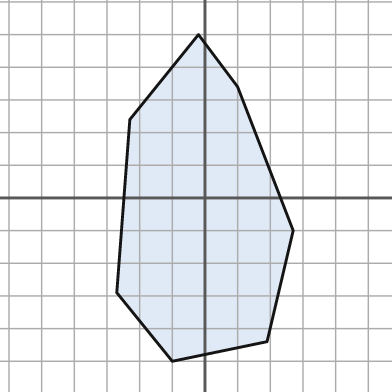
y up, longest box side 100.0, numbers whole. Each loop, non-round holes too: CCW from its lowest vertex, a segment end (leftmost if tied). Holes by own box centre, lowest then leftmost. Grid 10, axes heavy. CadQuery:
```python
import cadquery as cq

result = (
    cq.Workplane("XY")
    .moveTo(-10.0, -50.0)
    .lineTo(19.0, -44.0)
    .lineTo(27.0, -10.0)
    .lineTo(10.0, 34.0)
    .lineTo(-2.0, 50.0)
    .lineTo(-23.0, 24.0)
    .lineTo(-27.0, -29.0)
    .close()
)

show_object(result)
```